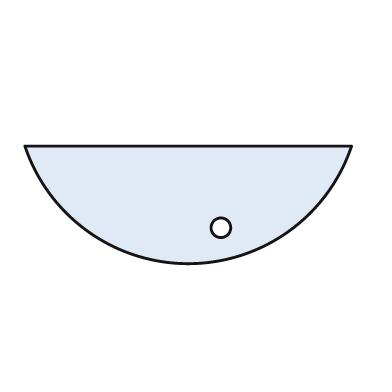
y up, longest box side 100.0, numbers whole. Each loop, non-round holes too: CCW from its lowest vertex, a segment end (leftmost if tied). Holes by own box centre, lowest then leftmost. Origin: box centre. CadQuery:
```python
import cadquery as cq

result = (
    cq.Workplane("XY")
    .moveTo(-50.0, 18.0)
    .threePointArc((0.0, -18.0), (50.0, 18.0))
    .close()
    .moveTo(10.0, -7.0)
    .circle(3.0)
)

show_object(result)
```